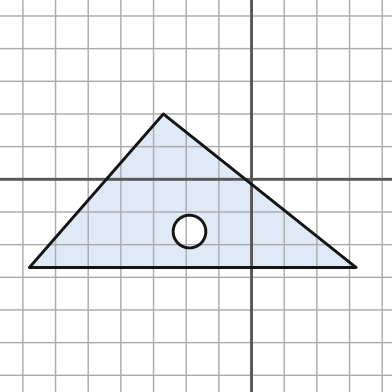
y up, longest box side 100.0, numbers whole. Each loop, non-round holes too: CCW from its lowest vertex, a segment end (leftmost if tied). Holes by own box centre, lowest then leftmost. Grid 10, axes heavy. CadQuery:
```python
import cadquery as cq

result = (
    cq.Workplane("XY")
    .moveTo(-68.0, -27.0)
    .lineTo(32.0, -27.0)
    .lineTo(-27.0, 20.0)
    .close()
    .moveTo(-19.0, -16.0)
    .circle(5.0)
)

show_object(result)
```